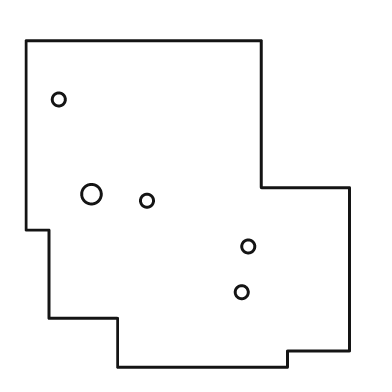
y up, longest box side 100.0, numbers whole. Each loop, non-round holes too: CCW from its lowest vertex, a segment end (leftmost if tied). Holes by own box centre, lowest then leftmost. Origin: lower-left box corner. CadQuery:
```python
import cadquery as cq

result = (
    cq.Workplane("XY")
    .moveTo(28.0, 0.0)
    .lineTo(80.0, 0.0)
    .lineTo(80.0, 5.0)
    .lineTo(99.0, 5.0)
    .lineTo(99.0, 55.0)
    .lineTo(72.0, 55.0)
    .lineTo(72.0, 100.0)
    .lineTo(0.0, 100.0)
    .lineTo(0.0, 42.0)
    .lineTo(7.0, 42.0)
    .lineTo(7.0, 15.0)
    .lineTo(28.0, 15.0)
    .close()
    .moveTo(66.0, 23.0)
    .circle(2.0)
    .moveTo(68.0, 37.0)
    .circle(2.0)
    .moveTo(37.0, 51.0)
    .circle(2.0)
    .moveTo(20.0, 53.0)
    .circle(3.0)
    .moveTo(10.0, 82.0)
    .circle(2.0)
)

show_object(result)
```